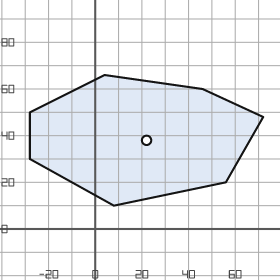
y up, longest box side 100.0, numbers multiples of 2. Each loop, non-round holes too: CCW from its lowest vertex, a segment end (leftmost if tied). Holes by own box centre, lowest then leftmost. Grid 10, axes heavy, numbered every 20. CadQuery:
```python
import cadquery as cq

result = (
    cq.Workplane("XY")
    .moveTo(8.0, 10.0)
    .lineTo(56.0, 20.0)
    .lineTo(72.0, 48.0)
    .lineTo(46.0, 60.0)
    .lineTo(4.0, 66.0)
    .lineTo(-28.0, 50.0)
    .lineTo(-28.0, 30.0)
    .close()
    .moveTo(22.0, 38.0)
    .circle(2.0)
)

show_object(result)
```